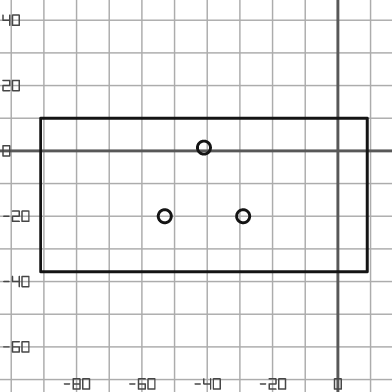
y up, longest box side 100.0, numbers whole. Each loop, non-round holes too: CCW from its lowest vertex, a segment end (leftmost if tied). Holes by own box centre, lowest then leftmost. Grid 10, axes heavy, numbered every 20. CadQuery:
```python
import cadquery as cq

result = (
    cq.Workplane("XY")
    .moveTo(-91.0, -37.0)
    .lineTo(9.0, -37.0)
    .lineTo(9.0, 10.0)
    .lineTo(-91.0, 10.0)
    .close()
    .moveTo(-53.0, -20.0)
    .circle(2.0)
    .moveTo(-29.0, -20.0)
    .circle(2.0)
    .moveTo(-41.0, 1.0)
    .circle(2.0)
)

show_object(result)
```